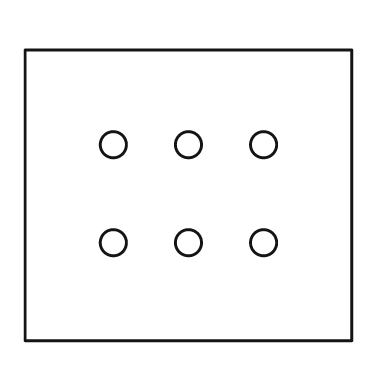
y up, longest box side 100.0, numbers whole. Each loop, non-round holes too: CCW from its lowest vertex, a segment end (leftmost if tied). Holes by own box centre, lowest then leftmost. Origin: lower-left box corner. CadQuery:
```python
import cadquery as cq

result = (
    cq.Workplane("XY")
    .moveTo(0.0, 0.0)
    .lineTo(100.0, 0.0)
    .lineTo(100.0, 89.0)
    .lineTo(0.0, 89.0)
    .close()
    .moveTo(27.0, 30.0)
    .circle(4.0)
    .moveTo(50.0, 30.0)
    .circle(4.0)
    .moveTo(73.0, 30.0)
    .circle(4.0)
    .moveTo(27.0, 60.0)
    .circle(4.0)
    .moveTo(50.0, 60.0)
    .circle(4.0)
    .moveTo(73.0, 60.0)
    .circle(4.0)
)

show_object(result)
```